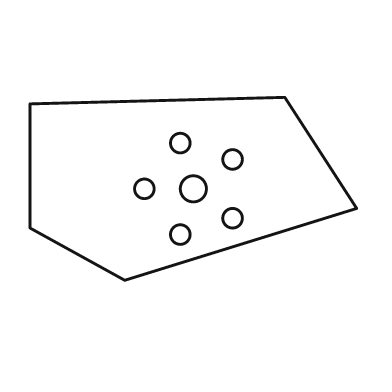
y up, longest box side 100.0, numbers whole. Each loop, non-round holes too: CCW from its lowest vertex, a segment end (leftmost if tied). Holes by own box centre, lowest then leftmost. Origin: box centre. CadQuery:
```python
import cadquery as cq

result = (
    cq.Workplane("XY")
    .moveTo(-21.0, -28.0)
    .lineTo(50.0, -6.0)
    .lineTo(28.0, 28.0)
    .lineTo(-50.0, 26.0)
    .lineTo(-50.0, -12.0)
    .close()
    .moveTo(-4.0, -14.0)
    .circle(3.0)
    .moveTo(12.0, -9.0)
    .circle(3.0)
    .moveTo(-15.0, 0.0)
    .circle(3.0)
    .moveTo(0.0, 0.0)
    .circle(4.0)
    .moveTo(12.0, 9.0)
    .circle(3.0)
    .moveTo(-4.0, 14.0)
    .circle(3.0)
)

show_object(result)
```